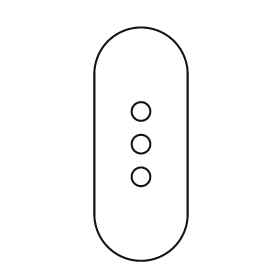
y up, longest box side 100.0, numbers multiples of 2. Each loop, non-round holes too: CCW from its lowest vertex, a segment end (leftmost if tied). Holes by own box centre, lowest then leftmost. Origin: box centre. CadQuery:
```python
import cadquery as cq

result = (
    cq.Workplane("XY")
    .moveTo(-20.0, -30.0)
    .threePointArc((0.0, -50.0), (20.0, -30.0))
    .lineTo(20.0, 30.0)
    .threePointArc((0.0, 50.0), (-20.0, 30.0))
    .close()
    .moveTo(0.0, -14.0)
    .circle(4.0)
    .moveTo(0.0, 0.0)
    .circle(4.0)
    .moveTo(0.0, 14.0)
    .circle(4.0)
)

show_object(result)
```